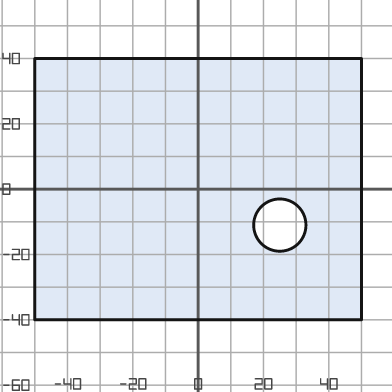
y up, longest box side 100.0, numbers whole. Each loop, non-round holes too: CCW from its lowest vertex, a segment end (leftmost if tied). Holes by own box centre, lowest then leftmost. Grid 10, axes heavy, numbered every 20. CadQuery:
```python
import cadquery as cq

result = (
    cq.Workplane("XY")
    .moveTo(-50.0, -40.0)
    .lineTo(50.0, -40.0)
    .lineTo(50.0, 40.0)
    .lineTo(-50.0, 40.0)
    .close()
    .moveTo(25.0, -11.0)
    .circle(8.0)
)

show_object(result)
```